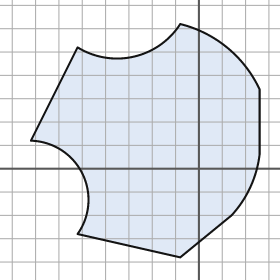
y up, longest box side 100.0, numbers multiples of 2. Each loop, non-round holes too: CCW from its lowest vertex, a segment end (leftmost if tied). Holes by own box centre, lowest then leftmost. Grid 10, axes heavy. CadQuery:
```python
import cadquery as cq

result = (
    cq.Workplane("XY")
    .moveTo(-8.0, -38.0)
    .lineTo(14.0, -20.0)
    .threePointArc((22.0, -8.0), (26.0, 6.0))
    .lineTo(26.0, 34.0)
    .threePointArc((12.0, 52.0), (-8.0, 62.0))
    .threePointArc((-28.0, 48.0), (-52.0, 52.0))
    .lineTo(-72.0, 12.0)
    .threePointArc((-50.0, -2.0), (-52.0, -28.0))
    .close()
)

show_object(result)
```